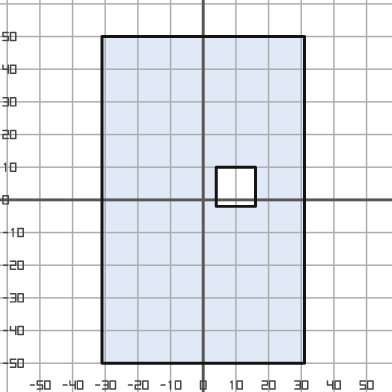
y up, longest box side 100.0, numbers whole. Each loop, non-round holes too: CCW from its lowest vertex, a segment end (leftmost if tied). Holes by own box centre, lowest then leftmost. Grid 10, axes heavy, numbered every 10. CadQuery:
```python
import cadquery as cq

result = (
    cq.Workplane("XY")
    .moveTo(-31.0, -50.0)
    .lineTo(31.0, -50.0)
    .lineTo(31.0, 50.0)
    .lineTo(-31.0, 50.0)
    .close()
    .moveTo(4.0, -2.0)
    .lineTo(16.0, -2.0)
    .lineTo(16.0, 10.0)
    .lineTo(4.0, 10.0)
    .close()
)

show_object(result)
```